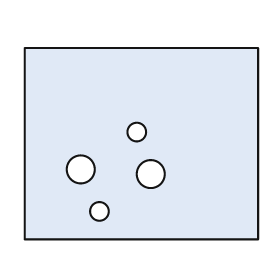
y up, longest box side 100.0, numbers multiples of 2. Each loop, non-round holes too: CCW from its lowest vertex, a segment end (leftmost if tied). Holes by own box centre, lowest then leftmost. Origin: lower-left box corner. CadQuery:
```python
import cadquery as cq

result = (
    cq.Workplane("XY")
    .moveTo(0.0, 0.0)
    .lineTo(100.0, 0.0)
    .lineTo(100.0, 82.0)
    .lineTo(0.0, 82.0)
    .close()
    .moveTo(32.0, 12.0)
    .circle(4.0)
    .moveTo(54.0, 28.0)
    .circle(6.0)
    .moveTo(24.0, 30.0)
    .circle(6.0)
    .moveTo(48.0, 46.0)
    .circle(4.0)
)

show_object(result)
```